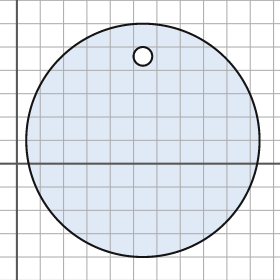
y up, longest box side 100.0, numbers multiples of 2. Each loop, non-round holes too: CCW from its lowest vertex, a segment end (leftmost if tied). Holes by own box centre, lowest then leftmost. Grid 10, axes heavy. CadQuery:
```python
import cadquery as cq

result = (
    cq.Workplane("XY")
    .moveTo(54.0, 10.0)
    .circle(50.0)
    .moveTo(54.0, 46.0)
    .circle(4.0)
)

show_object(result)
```